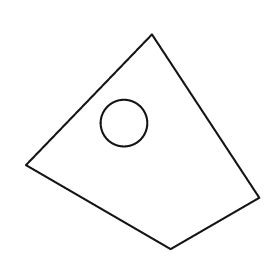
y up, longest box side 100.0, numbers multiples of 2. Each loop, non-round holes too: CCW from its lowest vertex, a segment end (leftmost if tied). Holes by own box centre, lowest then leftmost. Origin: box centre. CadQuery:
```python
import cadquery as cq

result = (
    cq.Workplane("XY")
    .moveTo(12.0, -46.0)
    .lineTo(50.0, -24.0)
    .lineTo(4.0, 46.0)
    .lineTo(-50.0, -10.0)
    .close()
    .moveTo(-8.0, 8.0)
    .circle(10.0)
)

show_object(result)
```